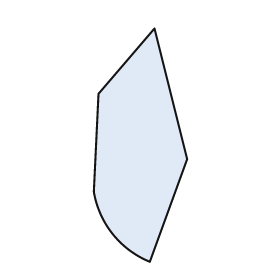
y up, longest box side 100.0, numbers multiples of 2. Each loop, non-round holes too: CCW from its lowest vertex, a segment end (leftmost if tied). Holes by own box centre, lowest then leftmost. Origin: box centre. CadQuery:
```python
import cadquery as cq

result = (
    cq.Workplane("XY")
    .moveTo(4.0, -50.0)
    .lineTo(20.0, -6.0)
    .lineTo(6.0, 50.0)
    .lineTo(-18.0, 22.0)
    .lineTo(-20.0, -20.0)
    .threePointArc((-12.0, -38.0), (4.0, -50.0))
    .close()
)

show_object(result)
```